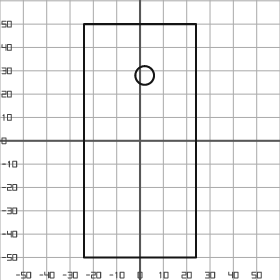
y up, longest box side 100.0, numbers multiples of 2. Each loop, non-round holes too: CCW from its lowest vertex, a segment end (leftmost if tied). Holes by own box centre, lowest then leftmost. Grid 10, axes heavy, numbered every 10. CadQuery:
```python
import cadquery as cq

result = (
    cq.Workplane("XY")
    .moveTo(-24.0, -50.0)
    .lineTo(24.0, -50.0)
    .lineTo(24.0, 50.0)
    .lineTo(-24.0, 50.0)
    .close()
    .moveTo(2.0, 28.0)
    .circle(4.0)
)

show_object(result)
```